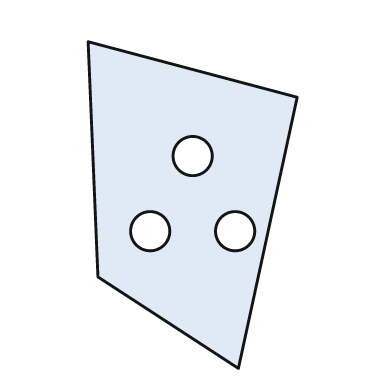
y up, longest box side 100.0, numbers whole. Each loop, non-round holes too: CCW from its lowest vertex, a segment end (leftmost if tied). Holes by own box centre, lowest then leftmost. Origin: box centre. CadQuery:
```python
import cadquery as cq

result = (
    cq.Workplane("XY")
    .moveTo(14.0, -50.0)
    .lineTo(32.0, 33.0)
    .lineTo(-32.0, 50.0)
    .lineTo(-29.0, -22.0)
    .close()
    .moveTo(-13.0, -8.0)
    .circle(6.0)
    .moveTo(13.0, -8.0)
    .circle(6.0)
    .moveTo(0.0, 15.0)
    .circle(6.0)
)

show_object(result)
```